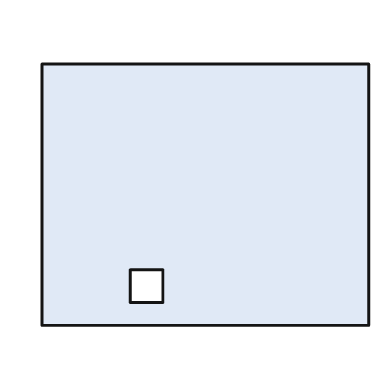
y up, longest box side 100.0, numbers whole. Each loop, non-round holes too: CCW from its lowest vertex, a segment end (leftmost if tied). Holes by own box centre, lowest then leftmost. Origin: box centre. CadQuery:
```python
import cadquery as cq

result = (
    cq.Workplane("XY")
    .moveTo(-50.0, -40.0)
    .lineTo(50.0, -40.0)
    .lineTo(50.0, 40.0)
    .lineTo(-50.0, 40.0)
    .close()
    .moveTo(-23.0, -33.0)
    .lineTo(-13.0, -33.0)
    .lineTo(-13.0, -23.0)
    .lineTo(-23.0, -23.0)
    .close()
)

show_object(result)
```